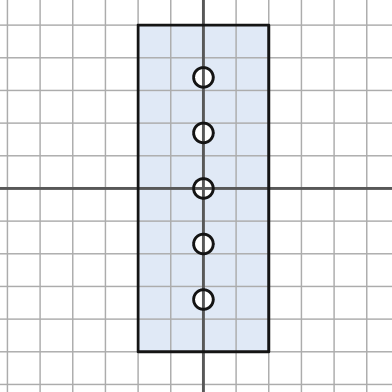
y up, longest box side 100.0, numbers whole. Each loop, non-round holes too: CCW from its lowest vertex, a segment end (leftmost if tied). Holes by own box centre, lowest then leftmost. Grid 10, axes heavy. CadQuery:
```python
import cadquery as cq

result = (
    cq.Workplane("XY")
    .moveTo(-20.0, -50.0)
    .lineTo(20.0, -50.0)
    .lineTo(20.0, 50.0)
    .lineTo(-20.0, 50.0)
    .close()
    .moveTo(0.0, -34.0)
    .circle(3.0)
    .moveTo(0.0, -17.0)
    .circle(3.0)
    .moveTo(0.0, 0.0)
    .circle(3.0)
    .moveTo(0.0, 17.0)
    .circle(3.0)
    .moveTo(0.0, 34.0)
    .circle(3.0)
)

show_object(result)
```